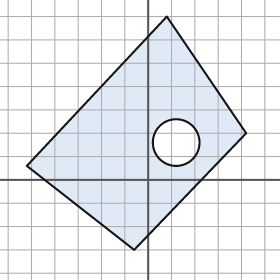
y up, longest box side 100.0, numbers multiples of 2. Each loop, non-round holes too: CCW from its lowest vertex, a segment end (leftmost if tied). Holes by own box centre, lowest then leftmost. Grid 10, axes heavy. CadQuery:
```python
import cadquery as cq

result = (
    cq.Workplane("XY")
    .moveTo(-6.0, -30.0)
    .lineTo(42.0, 20.0)
    .lineTo(8.0, 70.0)
    .lineTo(-52.0, 6.0)
    .close()
    .moveTo(12.0, 16.0)
    .circle(10.0)
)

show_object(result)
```